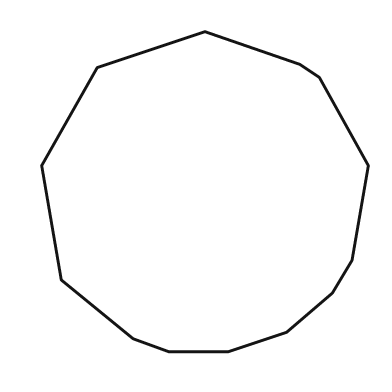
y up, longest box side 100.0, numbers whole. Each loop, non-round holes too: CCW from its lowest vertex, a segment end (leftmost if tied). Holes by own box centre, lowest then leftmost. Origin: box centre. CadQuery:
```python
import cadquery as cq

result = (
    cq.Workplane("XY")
    .moveTo(-11.0, -49.0)
    .lineTo(7.0, -49.0)
    .lineTo(25.0, -43.0)
    .lineTo(39.0, -31.0)
    .lineTo(45.0, -21.0)
    .lineTo(50.0, 8.0)
    .lineTo(35.0, 35.0)
    .lineTo(29.0, 39.0)
    .lineTo(0.0, 49.0)
    .lineTo(-33.0, 38.0)
    .lineTo(-50.0, 8.0)
    .lineTo(-44.0, -27.0)
    .lineTo(-22.0, -45.0)
    .close()
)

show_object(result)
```